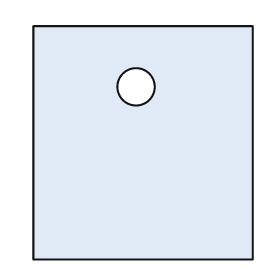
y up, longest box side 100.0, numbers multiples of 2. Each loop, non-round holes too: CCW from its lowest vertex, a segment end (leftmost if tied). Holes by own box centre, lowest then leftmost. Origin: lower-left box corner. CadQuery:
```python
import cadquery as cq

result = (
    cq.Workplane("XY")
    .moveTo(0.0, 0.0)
    .lineTo(94.0, 0.0)
    .lineTo(94.0, 100.0)
    .lineTo(0.0, 100.0)
    .close()
    .moveTo(44.0, 74.0)
    .circle(8.0)
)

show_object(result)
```